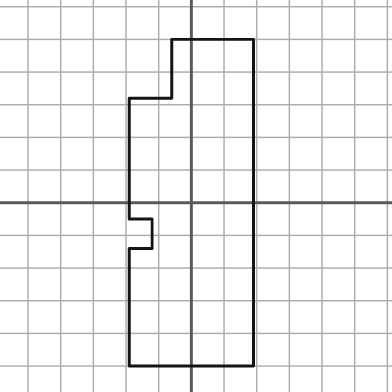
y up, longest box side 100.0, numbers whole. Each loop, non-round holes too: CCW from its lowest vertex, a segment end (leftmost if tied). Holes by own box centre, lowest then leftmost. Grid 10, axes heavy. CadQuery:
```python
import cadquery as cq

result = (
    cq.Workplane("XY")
    .moveTo(-19.0, -50.0)
    .lineTo(19.0, -50.0)
    .lineTo(19.0, 50.0)
    .lineTo(-6.0, 50.0)
    .lineTo(-6.0, 32.0)
    .lineTo(-19.0, 32.0)
    .lineTo(-19.0, -5.0)
    .lineTo(-12.0, -5.0)
    .lineTo(-12.0, -14.0)
    .lineTo(-19.0, -14.0)
    .close()
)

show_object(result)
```